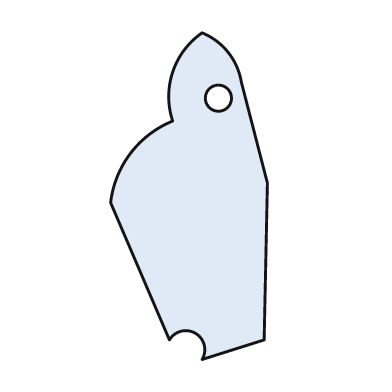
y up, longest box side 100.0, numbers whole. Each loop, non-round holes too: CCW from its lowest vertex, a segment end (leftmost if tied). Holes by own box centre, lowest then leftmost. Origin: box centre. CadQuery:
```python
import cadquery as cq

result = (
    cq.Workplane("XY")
    .moveTo(4.0, -50.0)
    .lineTo(23.0, -44.0)
    .lineTo(24.0, 4.0)
    .lineTo(16.0, 35.0)
    .threePointArc((12.0, 44.0), (4.0, 50.0))
    .threePointArc((-5.0, 38.0), (-5.0, 23.0))
    .threePointArc((-18.0, 13.0), (-24.0, -2.0))
    .lineTo(-6.0, -44.0)
    .threePointArc((2.0, -42.0), (4.0, -50.0))
    .close()
    .moveTo(9.0, 30.0)
    .circle(4.0)
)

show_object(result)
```